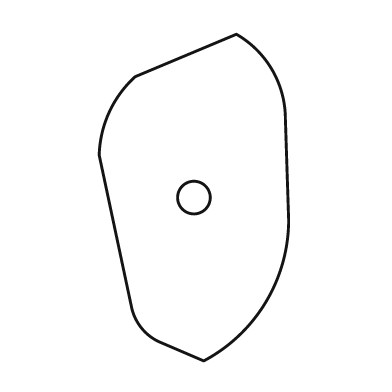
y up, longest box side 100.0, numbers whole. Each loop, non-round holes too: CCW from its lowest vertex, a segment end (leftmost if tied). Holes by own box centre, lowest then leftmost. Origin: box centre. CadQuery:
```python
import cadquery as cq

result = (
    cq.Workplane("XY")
    .moveTo(3.0, -50.0)
    .threePointArc((22.0, -32.0), (29.0, -7.0))
    .lineTo(28.0, 24.0)
    .threePointArc((24.0, 39.0), (13.0, 50.0))
    .lineTo(-18.0, 37.0)
    .threePointArc((-26.0, 26.0), (-29.0, 13.0))
    .lineTo(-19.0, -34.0)
    .threePointArc((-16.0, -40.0), (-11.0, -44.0))
    .close()
    .moveTo(0.0, 0.0)
    .circle(5.0)
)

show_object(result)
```